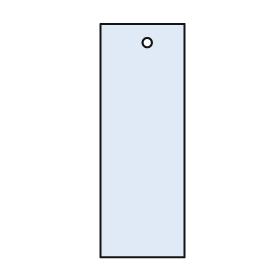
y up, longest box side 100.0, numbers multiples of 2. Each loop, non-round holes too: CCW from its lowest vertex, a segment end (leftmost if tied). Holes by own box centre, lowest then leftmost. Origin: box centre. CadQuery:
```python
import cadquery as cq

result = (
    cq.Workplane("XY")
    .moveTo(-18.0, -50.0)
    .lineTo(18.0, -50.0)
    .lineTo(18.0, 50.0)
    .lineTo(-18.0, 50.0)
    .close()
    .moveTo(2.0, 42.0)
    .circle(2.0)
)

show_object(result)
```